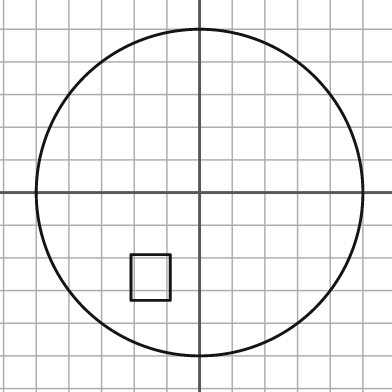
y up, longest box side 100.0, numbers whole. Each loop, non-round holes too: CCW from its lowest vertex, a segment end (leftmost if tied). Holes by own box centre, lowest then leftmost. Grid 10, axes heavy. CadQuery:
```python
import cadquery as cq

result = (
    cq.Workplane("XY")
    .moveTo(0.0, 0.0)
    .circle(50.0)
    .moveTo(-21.0, -33.0)
    .lineTo(-9.0, -33.0)
    .lineTo(-9.0, -19.0)
    .lineTo(-21.0, -19.0)
    .close()
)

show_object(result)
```